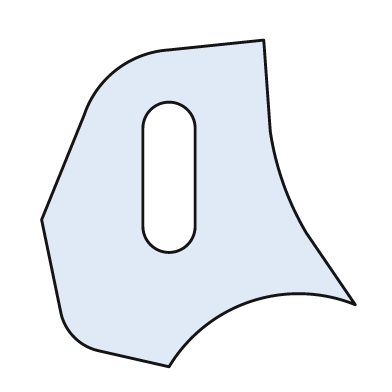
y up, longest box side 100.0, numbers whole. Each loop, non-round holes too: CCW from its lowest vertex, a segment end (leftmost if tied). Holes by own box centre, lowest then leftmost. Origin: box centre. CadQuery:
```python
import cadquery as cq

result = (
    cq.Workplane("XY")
    .moveTo(-9.0, -50.0)
    .threePointArc((16.0, -30.0), (48.0, -31.0))
    .lineTo(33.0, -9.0)
    .threePointArc((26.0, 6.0), (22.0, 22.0))
    .lineTo(20.0, 50.0)
    .lineTo(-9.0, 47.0)
    .threePointArc((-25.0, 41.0), (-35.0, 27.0))
    .lineTo(-48.0, -5.0)
    .lineTo(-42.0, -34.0)
    .threePointArc((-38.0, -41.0), (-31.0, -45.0))
    .close()
    .moveTo(-17.0, -7.0)
    .threePointArc((-9.0, -15.0), (-1.0, -7.0))
    .lineTo(-1.0, 23.0)
    .threePointArc((-9.0, 31.0), (-17.0, 23.0))
    .close()
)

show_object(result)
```